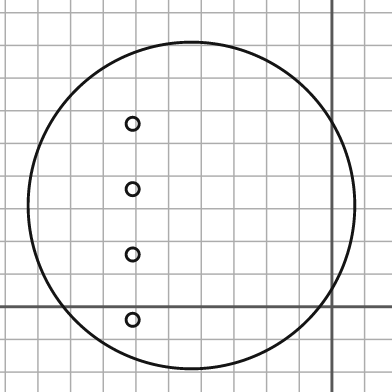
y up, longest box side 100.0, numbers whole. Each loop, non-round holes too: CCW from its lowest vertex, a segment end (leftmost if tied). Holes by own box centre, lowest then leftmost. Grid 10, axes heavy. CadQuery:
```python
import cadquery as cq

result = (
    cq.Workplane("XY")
    .moveTo(-43.0, 31.0)
    .circle(50.0)
    .moveTo(-61.0, -4.0)
    .circle(2.0)
    .moveTo(-61.0, 16.0)
    .circle(2.0)
    .moveTo(-61.0, 36.0)
    .circle(2.0)
    .moveTo(-61.0, 56.0)
    .circle(2.0)
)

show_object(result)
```